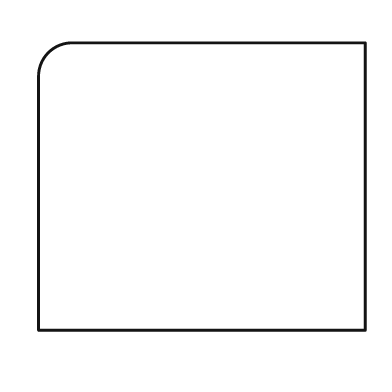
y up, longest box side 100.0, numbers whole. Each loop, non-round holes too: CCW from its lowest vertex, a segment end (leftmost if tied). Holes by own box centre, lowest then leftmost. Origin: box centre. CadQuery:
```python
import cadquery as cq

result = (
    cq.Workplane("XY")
    .moveTo(-50.0, -44.0)
    .lineTo(50.0, -44.0)
    .lineTo(50.0, 44.0)
    .lineTo(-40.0, 44.0)
    .threePointArc((-47.0, 41.0), (-50.0, 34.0))
    .close()
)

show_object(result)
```